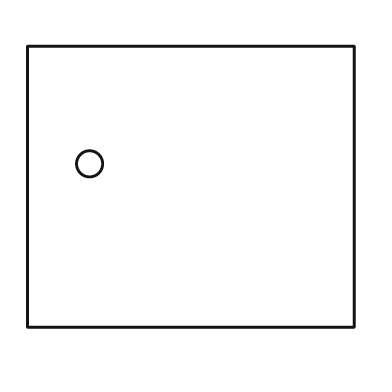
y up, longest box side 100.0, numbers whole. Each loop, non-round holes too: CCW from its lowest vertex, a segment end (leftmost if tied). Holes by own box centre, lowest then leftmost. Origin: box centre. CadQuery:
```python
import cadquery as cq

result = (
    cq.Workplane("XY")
    .moveTo(-50.0, -43.0)
    .lineTo(50.0, -43.0)
    .lineTo(50.0, 43.0)
    .lineTo(-50.0, 43.0)
    .close()
    .moveTo(-31.0, 7.0)
    .circle(4.0)
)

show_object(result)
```